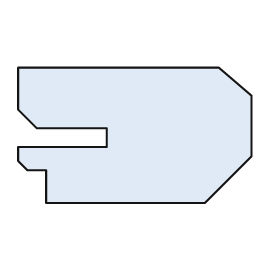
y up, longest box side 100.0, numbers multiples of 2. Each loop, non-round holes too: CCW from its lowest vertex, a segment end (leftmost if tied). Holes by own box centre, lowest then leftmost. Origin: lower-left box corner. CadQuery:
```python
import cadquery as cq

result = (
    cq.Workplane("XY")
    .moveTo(12.0, 0.0)
    .lineTo(80.0, 0.0)
    .lineTo(100.0, 20.0)
    .lineTo(100.0, 46.0)
    .lineTo(86.0, 58.0)
    .lineTo(0.0, 58.0)
    .lineTo(0.0, 40.0)
    .lineTo(8.0, 32.0)
    .lineTo(38.0, 32.0)
    .lineTo(38.0, 24.0)
    .lineTo(0.0, 24.0)
    .lineTo(0.0, 18.0)
    .lineTo(4.0, 14.0)
    .lineTo(12.0, 14.0)
    .close()
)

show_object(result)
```